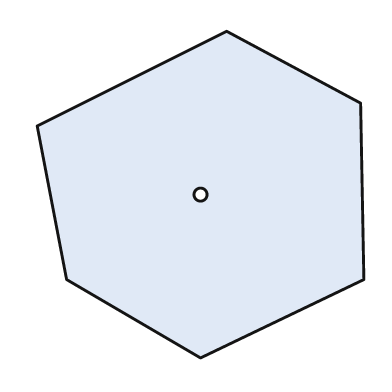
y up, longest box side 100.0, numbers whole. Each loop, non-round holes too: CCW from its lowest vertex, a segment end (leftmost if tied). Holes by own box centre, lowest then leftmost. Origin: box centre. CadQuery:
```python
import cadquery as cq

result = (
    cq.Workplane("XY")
    .moveTo(0.0, -50.0)
    .lineTo(50.0, -26.0)
    .lineTo(49.0, 28.0)
    .lineTo(8.0, 50.0)
    .lineTo(-50.0, 21.0)
    .lineTo(-41.0, -26.0)
    .close()
    .moveTo(0.0, 0.0)
    .circle(2.0)
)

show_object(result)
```